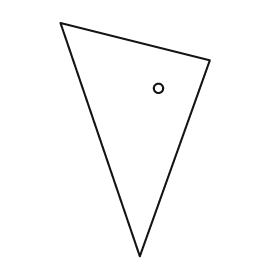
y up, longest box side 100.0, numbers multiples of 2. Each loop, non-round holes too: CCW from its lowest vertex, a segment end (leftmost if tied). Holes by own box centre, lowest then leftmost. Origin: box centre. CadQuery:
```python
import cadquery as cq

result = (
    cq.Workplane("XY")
    .moveTo(2.0, -50.0)
    .lineTo(32.0, 34.0)
    .lineTo(-32.0, 50.0)
    .close()
    .moveTo(10.0, 22.0)
    .circle(2.0)
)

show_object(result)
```